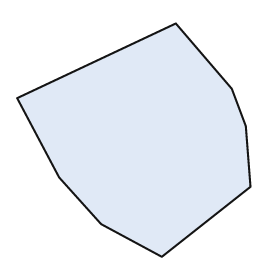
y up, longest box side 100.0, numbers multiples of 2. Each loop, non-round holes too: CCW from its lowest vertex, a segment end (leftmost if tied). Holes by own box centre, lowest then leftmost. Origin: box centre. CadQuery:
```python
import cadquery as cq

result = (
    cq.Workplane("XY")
    .moveTo(12.0, -50.0)
    .lineTo(50.0, -20.0)
    .lineTo(48.0, 6.0)
    .lineTo(42.0, 22.0)
    .lineTo(18.0, 50.0)
    .lineTo(-50.0, 18.0)
    .lineTo(-32.0, -16.0)
    .lineTo(-14.0, -36.0)
    .close()
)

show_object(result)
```